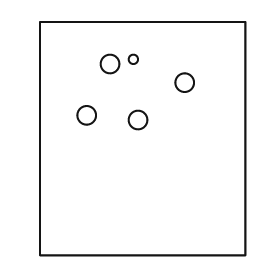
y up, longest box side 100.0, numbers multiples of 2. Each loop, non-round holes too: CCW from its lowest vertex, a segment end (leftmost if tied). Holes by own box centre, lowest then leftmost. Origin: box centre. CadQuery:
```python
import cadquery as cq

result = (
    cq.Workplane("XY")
    .moveTo(-44.0, -50.0)
    .lineTo(44.0, -50.0)
    .lineTo(44.0, 50.0)
    .lineTo(-44.0, 50.0)
    .close()
    .moveTo(-2.0, 8.0)
    .circle(4.0)
    .moveTo(-24.0, 10.0)
    .circle(4.0)
    .moveTo(18.0, 24.0)
    .circle(4.0)
    .moveTo(-14.0, 32.0)
    .circle(4.0)
    .moveTo(-4.0, 34.0)
    .circle(2.0)
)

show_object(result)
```